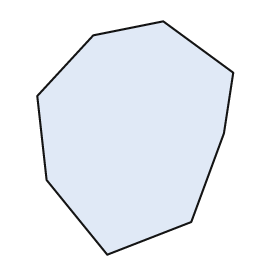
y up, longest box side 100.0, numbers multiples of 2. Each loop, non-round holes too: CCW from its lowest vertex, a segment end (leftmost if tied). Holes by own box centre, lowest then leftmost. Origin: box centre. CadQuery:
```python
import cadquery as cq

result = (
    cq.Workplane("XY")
    .moveTo(-12.0, -50.0)
    .lineTo(24.0, -36.0)
    .lineTo(38.0, 2.0)
    .lineTo(42.0, 28.0)
    .lineTo(12.0, 50.0)
    .lineTo(-18.0, 44.0)
    .lineTo(-42.0, 18.0)
    .lineTo(-38.0, -18.0)
    .close()
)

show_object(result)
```